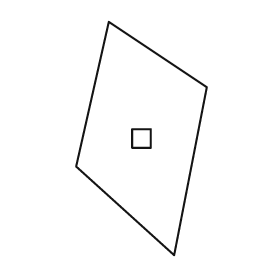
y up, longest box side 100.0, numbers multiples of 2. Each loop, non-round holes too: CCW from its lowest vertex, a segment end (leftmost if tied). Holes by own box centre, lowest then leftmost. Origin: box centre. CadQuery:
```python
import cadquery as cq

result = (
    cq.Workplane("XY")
    .moveTo(14.0, -50.0)
    .lineTo(28.0, 22.0)
    .lineTo(-14.0, 50.0)
    .lineTo(-28.0, -12.0)
    .close()
    .moveTo(-4.0, -4.0)
    .lineTo(4.0, -4.0)
    .lineTo(4.0, 4.0)
    .lineTo(-4.0, 4.0)
    .close()
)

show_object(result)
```